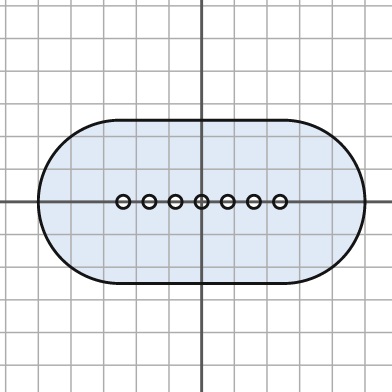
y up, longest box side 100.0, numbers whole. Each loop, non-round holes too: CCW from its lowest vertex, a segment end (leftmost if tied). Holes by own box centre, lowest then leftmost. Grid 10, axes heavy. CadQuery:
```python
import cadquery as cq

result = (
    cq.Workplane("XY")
    .moveTo(-25.0, -25.0)
    .lineTo(25.0, -25.0)
    .threePointArc((50.0, 0.0), (25.0, 25.0))
    .lineTo(-25.0, 25.0)
    .threePointArc((-50.0, 0.0), (-25.0, -25.0))
    .close()
    .moveTo(-24.0, 0.0)
    .circle(2.0)
    .moveTo(-16.0, 0.0)
    .circle(2.0)
    .moveTo(-8.0, 0.0)
    .circle(2.0)
    .moveTo(0.0, 0.0)
    .circle(2.0)
    .moveTo(8.0, 0.0)
    .circle(2.0)
    .moveTo(16.0, 0.0)
    .circle(2.0)
    .moveTo(24.0, 0.0)
    .circle(2.0)
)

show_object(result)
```